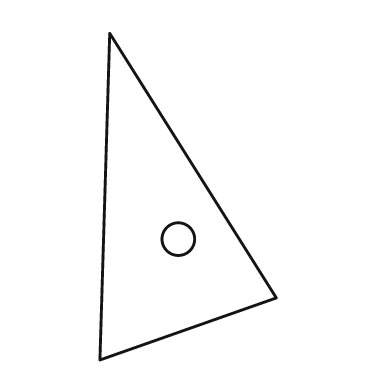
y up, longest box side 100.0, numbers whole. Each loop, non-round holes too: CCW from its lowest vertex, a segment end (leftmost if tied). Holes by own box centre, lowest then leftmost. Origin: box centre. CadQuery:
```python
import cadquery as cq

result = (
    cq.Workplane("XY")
    .moveTo(-27.0, -50.0)
    .lineTo(27.0, -31.0)
    .lineTo(-24.0, 50.0)
    .close()
    .moveTo(-3.0, -13.0)
    .circle(5.0)
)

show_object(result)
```